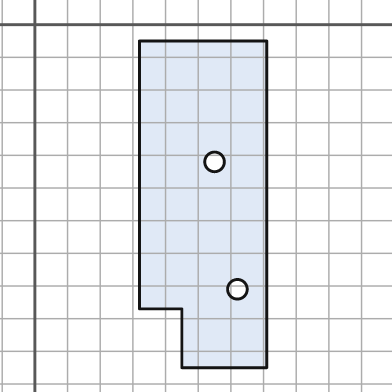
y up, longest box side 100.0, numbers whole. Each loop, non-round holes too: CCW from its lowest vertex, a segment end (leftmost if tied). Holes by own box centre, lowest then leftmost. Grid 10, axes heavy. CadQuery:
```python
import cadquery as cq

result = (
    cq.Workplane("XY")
    .moveTo(45.0, -105.0)
    .lineTo(71.0, -105.0)
    .lineTo(71.0, -5.0)
    .lineTo(32.0, -5.0)
    .lineTo(32.0, -87.0)
    .lineTo(45.0, -87.0)
    .close()
    .moveTo(62.0, -81.0)
    .circle(3.0)
    .moveTo(55.0, -42.0)
    .circle(3.0)
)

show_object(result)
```